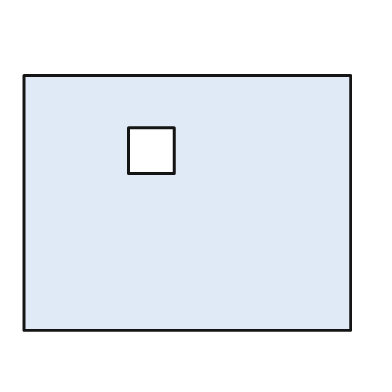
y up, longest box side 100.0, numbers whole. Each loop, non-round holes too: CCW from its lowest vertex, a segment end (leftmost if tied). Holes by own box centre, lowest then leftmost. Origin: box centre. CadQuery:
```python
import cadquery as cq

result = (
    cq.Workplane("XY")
    .moveTo(-50.0, -39.0)
    .lineTo(50.0, -39.0)
    .lineTo(50.0, 39.0)
    .lineTo(-50.0, 39.0)
    .close()
    .moveTo(-18.0, 9.0)
    .lineTo(-4.0, 9.0)
    .lineTo(-4.0, 23.0)
    .lineTo(-18.0, 23.0)
    .close()
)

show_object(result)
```